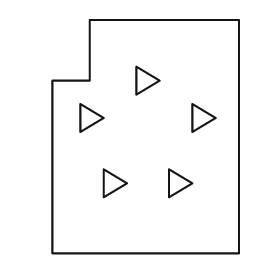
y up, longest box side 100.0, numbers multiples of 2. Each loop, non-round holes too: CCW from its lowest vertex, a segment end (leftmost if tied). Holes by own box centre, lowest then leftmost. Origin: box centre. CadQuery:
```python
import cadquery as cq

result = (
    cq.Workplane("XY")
    .moveTo(-40.0, -50.0)
    .lineTo(40.0, -50.0)
    .lineTo(40.0, 50.0)
    .lineTo(-24.0, 50.0)
    .lineTo(-24.0, 24.0)
    .lineTo(-40.0, 24.0)
    .close()
    .moveTo(-18.0, -26.0)
    .lineTo(-8.0, -20.0)
    .lineTo(-18.0, -14.0)
    .close()
    .moveTo(10.0, -26.0)
    .lineTo(20.0, -20.0)
    .lineTo(10.0, -14.0)
    .close()
    .moveTo(-28.0, 2.0)
    .lineTo(-18.0, 8.0)
    .lineTo(-28.0, 14.0)
    .close()
    .moveTo(20.0, 2.0)
    .lineTo(30.0, 8.0)
    .lineTo(20.0, 14.0)
    .close()
    .moveTo(-4.0, 18.0)
    .lineTo(6.0, 24.0)
    .lineTo(-4.0, 30.0)
    .close()
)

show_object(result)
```